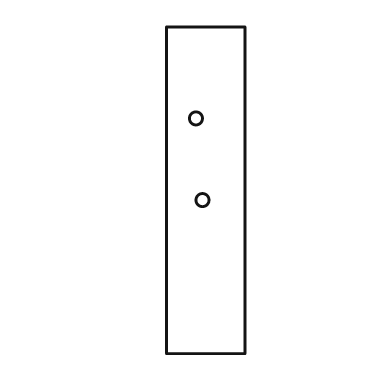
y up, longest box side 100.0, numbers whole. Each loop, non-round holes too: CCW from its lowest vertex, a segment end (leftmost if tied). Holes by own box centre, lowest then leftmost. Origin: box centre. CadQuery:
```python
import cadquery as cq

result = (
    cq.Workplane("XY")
    .moveTo(-12.0, -50.0)
    .lineTo(12.0, -50.0)
    .lineTo(12.0, 50.0)
    .lineTo(-12.0, 50.0)
    .close()
    .moveTo(-1.0, -3.0)
    .circle(2.0)
    .moveTo(-3.0, 22.0)
    .circle(2.0)
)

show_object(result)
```